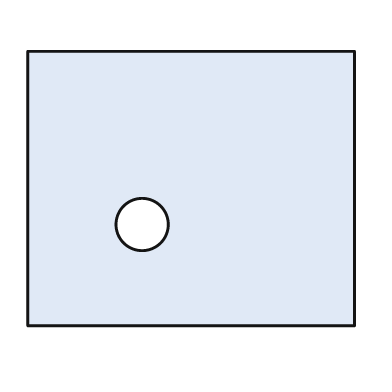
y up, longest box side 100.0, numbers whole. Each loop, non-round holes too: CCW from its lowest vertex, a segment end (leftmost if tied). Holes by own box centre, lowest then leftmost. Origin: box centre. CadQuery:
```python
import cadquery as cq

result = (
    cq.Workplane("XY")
    .moveTo(-50.0, -42.0)
    .lineTo(50.0, -42.0)
    .lineTo(50.0, 42.0)
    .lineTo(-50.0, 42.0)
    .close()
    .moveTo(-15.0, -11.0)
    .circle(8.0)
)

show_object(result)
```